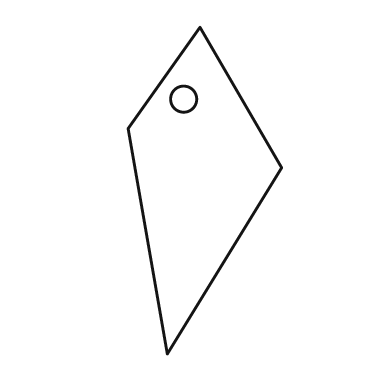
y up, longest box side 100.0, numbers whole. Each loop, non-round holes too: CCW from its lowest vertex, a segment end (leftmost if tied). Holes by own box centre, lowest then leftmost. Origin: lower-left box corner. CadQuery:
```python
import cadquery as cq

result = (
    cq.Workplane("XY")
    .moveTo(12.0, 0.0)
    .lineTo(47.0, 57.0)
    .lineTo(22.0, 100.0)
    .lineTo(0.0, 69.0)
    .close()
    .moveTo(17.0, 78.0)
    .circle(4.0)
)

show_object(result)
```